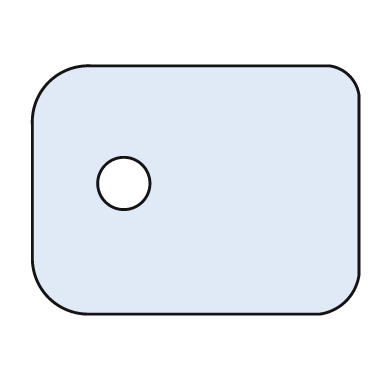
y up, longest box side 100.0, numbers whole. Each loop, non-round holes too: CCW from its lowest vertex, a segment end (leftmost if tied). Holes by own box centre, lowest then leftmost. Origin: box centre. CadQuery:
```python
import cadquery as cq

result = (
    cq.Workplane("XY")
    .moveTo(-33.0, -38.0)
    .lineTo(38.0, -38.0)
    .threePointArc((46.0, -34.0), (50.0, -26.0))
    .lineTo(50.0, 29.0)
    .threePointArc((47.0, 35.0), (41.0, 38.0))
    .lineTo(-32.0, 38.0)
    .threePointArc((-45.0, 33.0), (-50.0, 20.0))
    .lineTo(-50.0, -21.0)
    .threePointArc((-45.0, -33.0), (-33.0, -38.0))
    .close()
    .moveTo(-22.0, 2.0)
    .circle(8.0)
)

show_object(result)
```